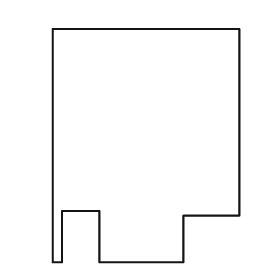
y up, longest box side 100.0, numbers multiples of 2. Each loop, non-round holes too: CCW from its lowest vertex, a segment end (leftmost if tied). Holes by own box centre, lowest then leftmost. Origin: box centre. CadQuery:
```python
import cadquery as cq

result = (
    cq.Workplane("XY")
    .moveTo(-40.0, -50.0)
    .lineTo(-36.0, -50.0)
    .lineTo(-36.0, -28.0)
    .lineTo(-20.0, -28.0)
    .lineTo(-20.0, -50.0)
    .lineTo(16.0, -50.0)
    .lineTo(16.0, -30.0)
    .lineTo(40.0, -30.0)
    .lineTo(40.0, 50.0)
    .lineTo(-40.0, 50.0)
    .close()
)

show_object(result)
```